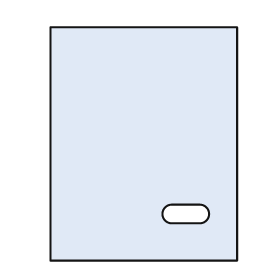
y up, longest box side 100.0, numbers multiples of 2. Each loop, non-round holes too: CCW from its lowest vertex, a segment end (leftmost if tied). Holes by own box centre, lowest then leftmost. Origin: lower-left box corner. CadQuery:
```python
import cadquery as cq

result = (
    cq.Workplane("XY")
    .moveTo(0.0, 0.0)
    .lineTo(80.0, 0.0)
    .lineTo(80.0, 100.0)
    .lineTo(0.0, 100.0)
    .close()
    .moveTo(52.0, 16.0)
    .lineTo(64.0, 16.0)
    .threePointArc((68.0, 20.0), (64.0, 24.0))
    .lineTo(52.0, 24.0)
    .threePointArc((48.0, 20.0), (52.0, 16.0))
    .close()
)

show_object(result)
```